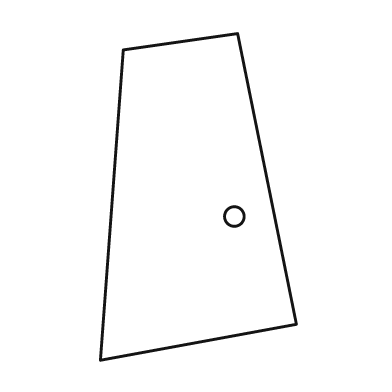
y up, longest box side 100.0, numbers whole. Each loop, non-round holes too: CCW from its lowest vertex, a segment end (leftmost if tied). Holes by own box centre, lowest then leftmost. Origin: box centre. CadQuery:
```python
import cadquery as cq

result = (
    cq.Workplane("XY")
    .moveTo(-30.0, -50.0)
    .lineTo(30.0, -39.0)
    .lineTo(12.0, 50.0)
    .lineTo(-23.0, 45.0)
    .close()
    .moveTo(11.0, -6.0)
    .circle(3.0)
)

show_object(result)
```